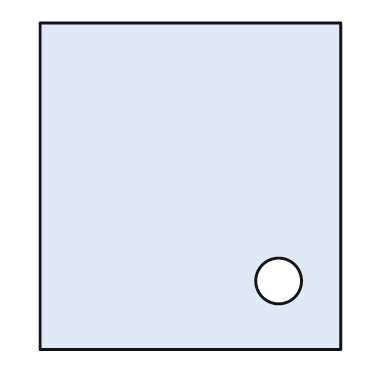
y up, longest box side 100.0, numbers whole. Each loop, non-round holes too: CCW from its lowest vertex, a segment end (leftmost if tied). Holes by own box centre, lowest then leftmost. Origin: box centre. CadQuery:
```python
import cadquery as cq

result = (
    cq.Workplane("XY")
    .moveTo(-46.0, -50.0)
    .lineTo(46.0, -50.0)
    .lineTo(46.0, 50.0)
    .lineTo(-46.0, 50.0)
    .close()
    .moveTo(27.0, -29.0)
    .circle(7.0)
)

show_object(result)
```